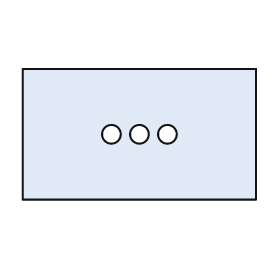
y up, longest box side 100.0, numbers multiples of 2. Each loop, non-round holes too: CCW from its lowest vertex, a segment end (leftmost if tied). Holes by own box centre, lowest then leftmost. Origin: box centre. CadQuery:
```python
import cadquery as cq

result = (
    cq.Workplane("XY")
    .moveTo(-50.0, -28.0)
    .lineTo(50.0, -28.0)
    .lineTo(50.0, 28.0)
    .lineTo(-50.0, 28.0)
    .close()
    .moveTo(-12.0, 0.0)
    .circle(4.0)
    .moveTo(0.0, 0.0)
    .circle(4.0)
    .moveTo(12.0, 0.0)
    .circle(4.0)
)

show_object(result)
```